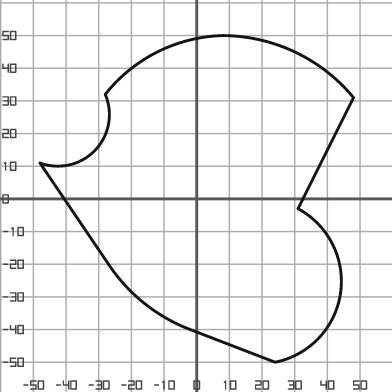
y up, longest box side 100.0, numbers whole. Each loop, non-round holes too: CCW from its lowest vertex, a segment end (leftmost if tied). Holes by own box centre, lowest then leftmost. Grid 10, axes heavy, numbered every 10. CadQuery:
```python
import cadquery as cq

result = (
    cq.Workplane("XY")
    .moveTo(24.0, -50.0)
    .threePointArc((44.0, -29.0), (31.0, -3.0))
    .lineTo(48.0, 31.0)
    .threePointArc((30.0, 45.0), (8.0, 50.0))
    .threePointArc((-12.0, 45.0), (-28.0, 32.0))
    .threePointArc((-31.0, 15.0), (-48.0, 11.0))
    .lineTo(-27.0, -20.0)
    .threePointArc((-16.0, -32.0), (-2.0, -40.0))
    .close()
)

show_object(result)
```